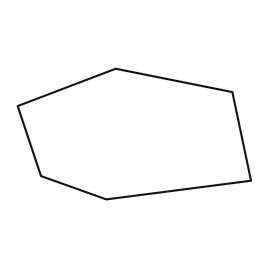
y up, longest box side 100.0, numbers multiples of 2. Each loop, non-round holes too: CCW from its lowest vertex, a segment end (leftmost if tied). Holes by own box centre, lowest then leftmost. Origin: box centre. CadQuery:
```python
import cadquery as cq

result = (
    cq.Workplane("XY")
    .moveTo(-12.0, -28.0)
    .lineTo(50.0, -20.0)
    .lineTo(42.0, 18.0)
    .lineTo(-8.0, 28.0)
    .lineTo(-50.0, 12.0)
    .lineTo(-40.0, -18.0)
    .close()
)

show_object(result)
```